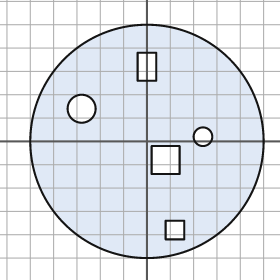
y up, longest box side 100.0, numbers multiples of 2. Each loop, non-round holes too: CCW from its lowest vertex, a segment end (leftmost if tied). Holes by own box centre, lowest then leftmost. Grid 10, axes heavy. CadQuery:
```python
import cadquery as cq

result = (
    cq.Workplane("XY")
    .moveTo(0.0, 0.0)
    .circle(50.0)
    .moveTo(8.0, -42.0)
    .lineTo(16.0, -42.0)
    .lineTo(16.0, -34.0)
    .lineTo(8.0, -34.0)
    .close()
    .moveTo(2.0, -14.0)
    .lineTo(14.0, -14.0)
    .lineTo(14.0, -2.0)
    .lineTo(2.0, -2.0)
    .close()
    .moveTo(24.0, 2.0)
    .circle(4.0)
    .moveTo(-28.0, 14.0)
    .circle(6.0)
    .moveTo(-4.0, 26.0)
    .lineTo(4.0, 26.0)
    .lineTo(4.0, 38.0)
    .lineTo(-4.0, 38.0)
    .close()
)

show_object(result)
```